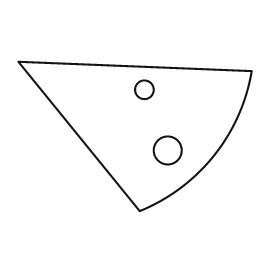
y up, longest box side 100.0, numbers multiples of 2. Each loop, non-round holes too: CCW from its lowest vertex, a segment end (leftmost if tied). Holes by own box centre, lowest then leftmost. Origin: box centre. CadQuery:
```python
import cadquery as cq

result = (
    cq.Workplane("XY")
    .moveTo(2.0, -32.0)
    .threePointArc((34.0, -8.0), (50.0, 28.0))
    .lineTo(-50.0, 32.0)
    .close()
    .moveTo(14.0, -6.0)
    .circle(6.0)
    .moveTo(4.0, 20.0)
    .circle(4.0)
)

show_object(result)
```